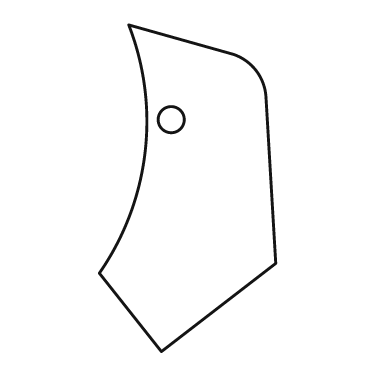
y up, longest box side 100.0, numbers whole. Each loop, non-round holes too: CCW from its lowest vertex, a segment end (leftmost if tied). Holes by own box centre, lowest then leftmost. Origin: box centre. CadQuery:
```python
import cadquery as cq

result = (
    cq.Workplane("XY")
    .moveTo(-8.0, -50.0)
    .lineTo(27.0, -23.0)
    .lineTo(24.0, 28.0)
    .threePointArc((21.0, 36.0), (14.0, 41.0))
    .lineTo(-18.0, 50.0)
    .threePointArc((-13.0, 11.0), (-27.0, -26.0))
    .close()
    .moveTo(-5.0, 21.0)
    .circle(4.0)
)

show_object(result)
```